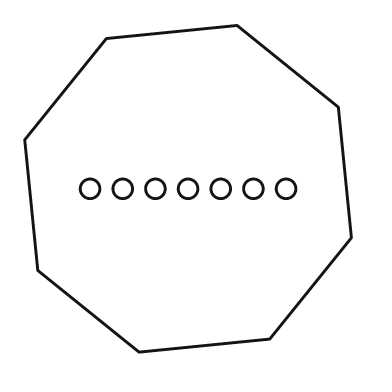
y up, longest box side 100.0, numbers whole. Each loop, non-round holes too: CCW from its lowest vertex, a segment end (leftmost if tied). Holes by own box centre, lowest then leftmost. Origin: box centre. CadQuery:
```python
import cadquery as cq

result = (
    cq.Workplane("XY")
    .moveTo(-15.0, -50.0)
    .lineTo(25.0, -46.0)
    .lineTo(50.0, -15.0)
    .lineTo(46.0, 25.0)
    .lineTo(15.0, 50.0)
    .lineTo(-25.0, 46.0)
    .lineTo(-50.0, 15.0)
    .lineTo(-46.0, -25.0)
    .close()
    .moveTo(-30.0, 0.0)
    .circle(3.0)
    .moveTo(-20.0, 0.0)
    .circle(3.0)
    .moveTo(-10.0, 0.0)
    .circle(3.0)
    .moveTo(0.0, 0.0)
    .circle(3.0)
    .moveTo(10.0, 0.0)
    .circle(3.0)
    .moveTo(20.0, 0.0)
    .circle(3.0)
    .moveTo(30.0, 0.0)
    .circle(3.0)
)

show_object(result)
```